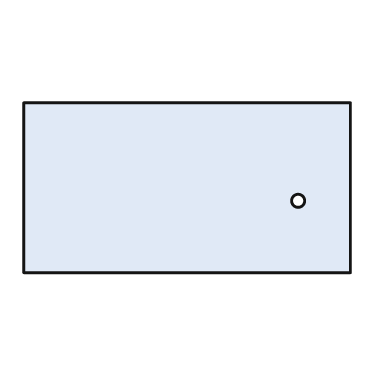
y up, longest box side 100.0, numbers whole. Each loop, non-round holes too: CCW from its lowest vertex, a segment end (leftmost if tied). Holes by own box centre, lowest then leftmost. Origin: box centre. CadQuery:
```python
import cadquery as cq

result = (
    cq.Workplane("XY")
    .moveTo(-50.0, -26.0)
    .lineTo(50.0, -26.0)
    .lineTo(50.0, 26.0)
    .lineTo(-50.0, 26.0)
    .close()
    .moveTo(34.0, -4.0)
    .circle(2.0)
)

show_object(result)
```